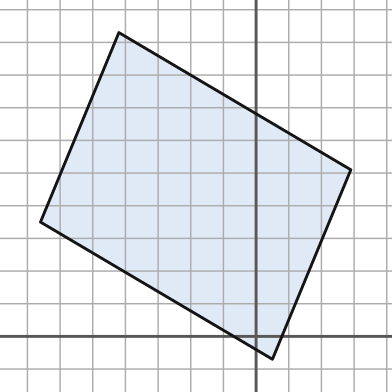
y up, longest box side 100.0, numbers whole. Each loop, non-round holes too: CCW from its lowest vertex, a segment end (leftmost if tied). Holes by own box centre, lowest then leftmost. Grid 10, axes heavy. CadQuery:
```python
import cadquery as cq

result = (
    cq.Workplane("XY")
    .moveTo(5.0, -7.0)
    .lineTo(29.0, 51.0)
    .lineTo(-42.0, 93.0)
    .lineTo(-66.0, 35.0)
    .close()
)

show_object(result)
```